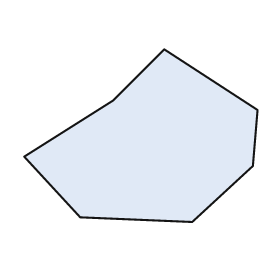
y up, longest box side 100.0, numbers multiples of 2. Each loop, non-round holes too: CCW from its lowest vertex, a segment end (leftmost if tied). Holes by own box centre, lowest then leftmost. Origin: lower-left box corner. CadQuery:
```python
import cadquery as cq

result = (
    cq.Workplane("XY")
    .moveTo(72.0, 0.0)
    .lineTo(98.0, 24.0)
    .lineTo(100.0, 48.0)
    .lineTo(60.0, 74.0)
    .lineTo(38.0, 52.0)
    .lineTo(0.0, 28.0)
    .lineTo(24.0, 2.0)
    .close()
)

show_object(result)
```